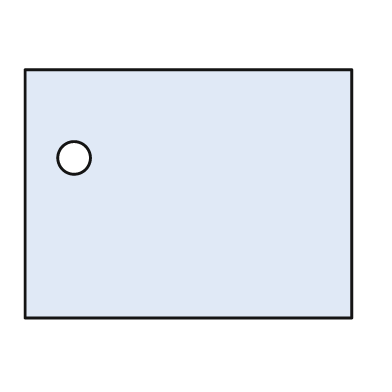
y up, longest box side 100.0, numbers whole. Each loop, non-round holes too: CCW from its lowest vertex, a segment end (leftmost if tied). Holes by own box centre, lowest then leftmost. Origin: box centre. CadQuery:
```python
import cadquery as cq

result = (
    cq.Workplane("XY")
    .moveTo(-50.0, -38.0)
    .lineTo(50.0, -38.0)
    .lineTo(50.0, 38.0)
    .lineTo(-50.0, 38.0)
    .close()
    .moveTo(-35.0, 11.0)
    .circle(5.0)
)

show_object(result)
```